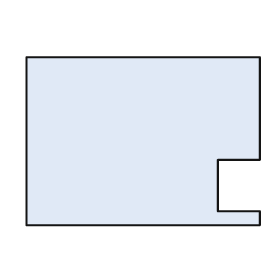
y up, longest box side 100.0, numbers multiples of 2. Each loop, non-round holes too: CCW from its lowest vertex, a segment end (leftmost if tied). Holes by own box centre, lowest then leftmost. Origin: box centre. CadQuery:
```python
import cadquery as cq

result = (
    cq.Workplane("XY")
    .moveTo(-50.0, -36.0)
    .lineTo(50.0, -36.0)
    .lineTo(50.0, -30.0)
    .lineTo(32.0, -30.0)
    .lineTo(32.0, -8.0)
    .lineTo(50.0, -8.0)
    .lineTo(50.0, 36.0)
    .lineTo(-50.0, 36.0)
    .close()
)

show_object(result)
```